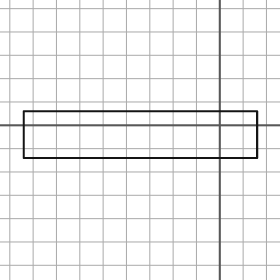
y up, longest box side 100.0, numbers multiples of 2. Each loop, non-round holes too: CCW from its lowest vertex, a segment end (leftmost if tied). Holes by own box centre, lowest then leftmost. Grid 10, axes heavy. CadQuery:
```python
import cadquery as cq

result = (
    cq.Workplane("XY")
    .moveTo(-84.0, -14.0)
    .lineTo(16.0, -14.0)
    .lineTo(16.0, 6.0)
    .lineTo(-84.0, 6.0)
    .close()
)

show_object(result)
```